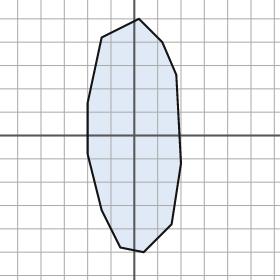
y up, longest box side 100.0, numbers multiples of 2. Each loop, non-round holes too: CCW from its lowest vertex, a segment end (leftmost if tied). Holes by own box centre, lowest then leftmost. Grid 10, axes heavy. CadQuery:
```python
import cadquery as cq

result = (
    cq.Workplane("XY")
    .moveTo(4.0, -50.0)
    .lineTo(16.0, -38.0)
    .lineTo(20.0, -12.0)
    .lineTo(18.0, 26.0)
    .lineTo(12.0, 40.0)
    .lineTo(2.0, 50.0)
    .lineTo(-14.0, 42.0)
    .lineTo(-20.0, 14.0)
    .lineTo(-20.0, -8.0)
    .lineTo(-14.0, -32.0)
    .lineTo(-6.0, -48.0)
    .close()
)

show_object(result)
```